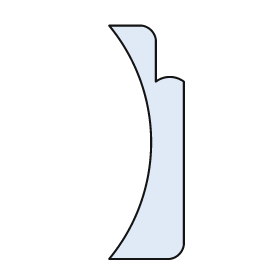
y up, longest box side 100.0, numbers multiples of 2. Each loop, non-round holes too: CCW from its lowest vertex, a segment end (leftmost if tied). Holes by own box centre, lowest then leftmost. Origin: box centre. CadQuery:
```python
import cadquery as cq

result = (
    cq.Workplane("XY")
    .moveTo(-16.0, -50.0)
    .lineTo(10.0, -50.0)
    .threePointArc((14.0, -48.0), (16.0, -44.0))
    .lineTo(16.0, 26.0)
    .threePointArc((10.0, 28.0), (4.0, 26.0))
    .lineTo(4.0, 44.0)
    .threePointArc((2.0, 48.0), (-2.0, 50.0))
    .lineTo(-16.0, 50.0)
    .threePointArc((2.0, 0.0), (-16.0, -50.0))
    .close()
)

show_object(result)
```